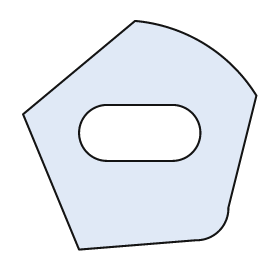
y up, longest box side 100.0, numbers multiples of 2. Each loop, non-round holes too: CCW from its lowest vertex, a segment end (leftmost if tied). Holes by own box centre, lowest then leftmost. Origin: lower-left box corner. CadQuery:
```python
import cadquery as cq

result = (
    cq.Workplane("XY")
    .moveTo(24.0, 0.0)
    .lineTo(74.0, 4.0)
    .threePointArc((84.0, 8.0), (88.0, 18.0))
    .lineTo(100.0, 66.0)
    .threePointArc((78.0, 88.0), (48.0, 98.0))
    .lineTo(0.0, 58.0)
    .close()
    .moveTo(36.0, 38.0)
    .lineTo(64.0, 38.0)
    .threePointArc((76.0, 50.0), (64.0, 62.0))
    .lineTo(36.0, 62.0)
    .threePointArc((24.0, 50.0), (36.0, 38.0))
    .close()
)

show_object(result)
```